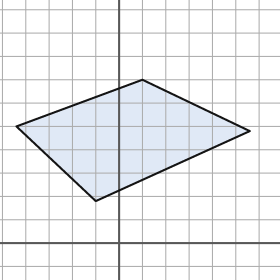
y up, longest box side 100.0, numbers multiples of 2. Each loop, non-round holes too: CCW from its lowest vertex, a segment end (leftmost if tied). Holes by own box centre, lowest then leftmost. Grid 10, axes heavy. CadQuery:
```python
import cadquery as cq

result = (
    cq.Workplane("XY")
    .moveTo(-10.0, 18.0)
    .lineTo(56.0, 48.0)
    .lineTo(10.0, 70.0)
    .lineTo(-44.0, 50.0)
    .close()
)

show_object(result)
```